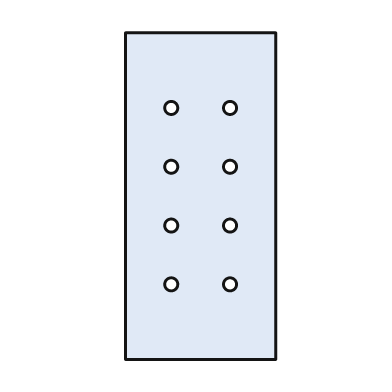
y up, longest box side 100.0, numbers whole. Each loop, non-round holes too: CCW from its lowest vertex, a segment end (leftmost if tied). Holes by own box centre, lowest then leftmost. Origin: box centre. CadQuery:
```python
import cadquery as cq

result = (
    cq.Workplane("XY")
    .moveTo(-23.0, -50.0)
    .lineTo(23.0, -50.0)
    .lineTo(23.0, 50.0)
    .lineTo(-23.0, 50.0)
    .close()
    .moveTo(-9.0, -27.0)
    .circle(2.0)
    .moveTo(9.0, -27.0)
    .circle(2.0)
    .moveTo(-9.0, -9.0)
    .circle(2.0)
    .moveTo(9.0, -9.0)
    .circle(2.0)
    .moveTo(-9.0, 9.0)
    .circle(2.0)
    .moveTo(9.0, 9.0)
    .circle(2.0)
    .moveTo(-9.0, 27.0)
    .circle(2.0)
    .moveTo(9.0, 27.0)
    .circle(2.0)
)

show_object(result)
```